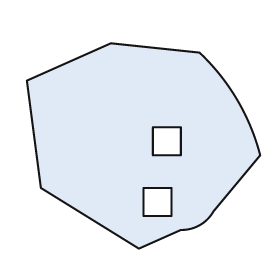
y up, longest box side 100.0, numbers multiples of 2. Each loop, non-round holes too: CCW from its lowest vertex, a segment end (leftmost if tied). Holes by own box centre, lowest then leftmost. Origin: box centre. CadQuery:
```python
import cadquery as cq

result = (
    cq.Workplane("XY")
    .moveTo(-2.0, -44.0)
    .lineTo(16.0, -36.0)
    .threePointArc((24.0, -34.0), (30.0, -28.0))
    .lineTo(50.0, -4.0)
    .threePointArc((40.0, 20.0), (24.0, 40.0))
    .lineTo(-14.0, 44.0)
    .lineTo(-50.0, 28.0)
    .lineTo(-44.0, -18.0)
    .close()
    .moveTo(0.0, -30.0)
    .lineTo(12.0, -30.0)
    .lineTo(12.0, -18.0)
    .lineTo(0.0, -18.0)
    .close()
    .moveTo(4.0, -4.0)
    .lineTo(16.0, -4.0)
    .lineTo(16.0, 8.0)
    .lineTo(4.0, 8.0)
    .close()
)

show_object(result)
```